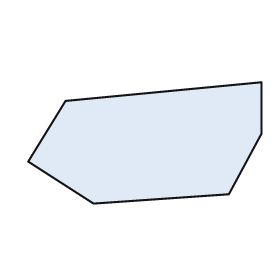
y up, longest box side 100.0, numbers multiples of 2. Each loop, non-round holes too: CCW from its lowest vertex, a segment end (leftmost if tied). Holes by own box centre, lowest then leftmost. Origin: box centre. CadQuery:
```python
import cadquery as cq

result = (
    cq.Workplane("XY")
    .moveTo(-22.0, -26.0)
    .lineTo(36.0, -22.0)
    .lineTo(50.0, 4.0)
    .lineTo(50.0, 26.0)
    .lineTo(-34.0, 18.0)
    .lineTo(-50.0, -8.0)
    .close()
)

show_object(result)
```